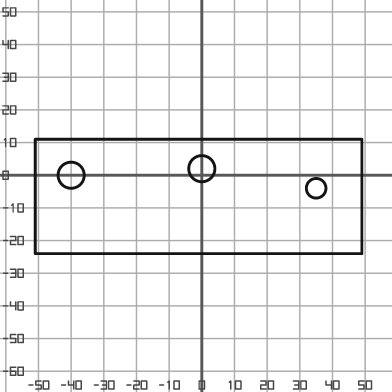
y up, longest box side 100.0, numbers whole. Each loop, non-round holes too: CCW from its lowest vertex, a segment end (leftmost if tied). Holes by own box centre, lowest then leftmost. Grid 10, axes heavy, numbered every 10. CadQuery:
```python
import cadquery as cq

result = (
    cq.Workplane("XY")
    .moveTo(-51.0, -24.0)
    .lineTo(49.0, -24.0)
    .lineTo(49.0, 11.0)
    .lineTo(-51.0, 11.0)
    .close()
    .moveTo(35.0, -4.0)
    .circle(3.0)
    .moveTo(-40.0, 0.0)
    .circle(4.0)
    .moveTo(0.0, 2.0)
    .circle(4.0)
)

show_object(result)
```